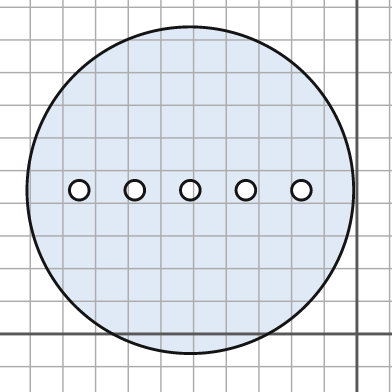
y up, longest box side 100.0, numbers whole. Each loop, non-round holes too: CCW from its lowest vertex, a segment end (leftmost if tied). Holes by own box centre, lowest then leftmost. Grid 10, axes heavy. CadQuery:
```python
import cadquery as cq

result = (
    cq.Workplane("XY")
    .moveTo(-51.0, 44.0)
    .circle(50.0)
    .moveTo(-85.0, 44.0)
    .circle(3.0)
    .moveTo(-68.0, 44.0)
    .circle(3.0)
    .moveTo(-51.0, 44.0)
    .circle(3.0)
    .moveTo(-34.0, 44.0)
    .circle(3.0)
    .moveTo(-17.0, 44.0)
    .circle(3.0)
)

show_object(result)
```